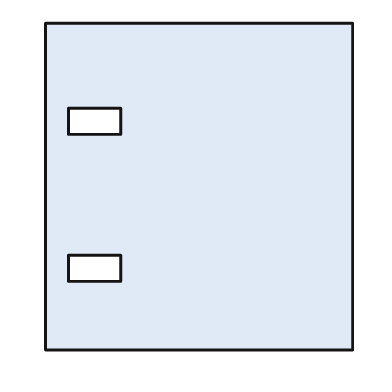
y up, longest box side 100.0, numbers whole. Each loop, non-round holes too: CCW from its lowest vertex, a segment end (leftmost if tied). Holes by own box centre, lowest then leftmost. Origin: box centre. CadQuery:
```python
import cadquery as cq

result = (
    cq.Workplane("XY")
    .moveTo(-47.0, -50.0)
    .lineTo(47.0, -50.0)
    .lineTo(47.0, 50.0)
    .lineTo(-47.0, 50.0)
    .close()
    .moveTo(-40.0, -29.0)
    .lineTo(-24.0, -29.0)
    .lineTo(-24.0, -21.0)
    .lineTo(-40.0, -21.0)
    .close()
    .moveTo(-40.0, 16.0)
    .lineTo(-24.0, 16.0)
    .lineTo(-24.0, 24.0)
    .lineTo(-40.0, 24.0)
    .close()
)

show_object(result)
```